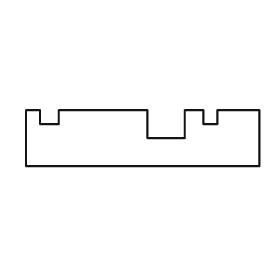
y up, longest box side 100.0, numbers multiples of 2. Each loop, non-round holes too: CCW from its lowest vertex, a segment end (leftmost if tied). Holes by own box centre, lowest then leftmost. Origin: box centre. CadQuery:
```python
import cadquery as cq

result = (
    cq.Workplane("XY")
    .moveTo(-50.0, -12.0)
    .lineTo(50.0, -12.0)
    .lineTo(50.0, 12.0)
    .lineTo(32.0, 12.0)
    .lineTo(32.0, 6.0)
    .lineTo(26.0, 6.0)
    .lineTo(26.0, 12.0)
    .lineTo(18.0, 12.0)
    .lineTo(18.0, 0.0)
    .lineTo(2.0, 0.0)
    .lineTo(2.0, 12.0)
    .lineTo(-36.0, 12.0)
    .lineTo(-36.0, 6.0)
    .lineTo(-44.0, 6.0)
    .lineTo(-44.0, 12.0)
    .lineTo(-50.0, 12.0)
    .close()
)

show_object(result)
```